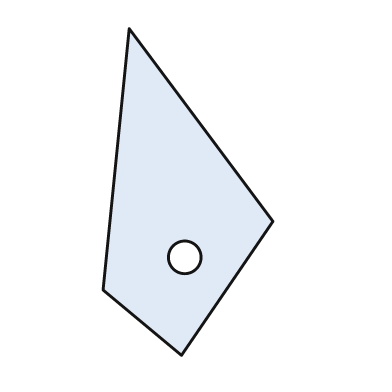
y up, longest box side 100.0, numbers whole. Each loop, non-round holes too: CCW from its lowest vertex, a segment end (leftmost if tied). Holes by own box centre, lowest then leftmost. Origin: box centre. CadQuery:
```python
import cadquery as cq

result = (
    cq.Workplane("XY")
    .moveTo(-2.0, -50.0)
    .lineTo(26.0, -9.0)
    .lineTo(-18.0, 50.0)
    .lineTo(-26.0, -30.0)
    .close()
    .moveTo(-1.0, -20.0)
    .circle(5.0)
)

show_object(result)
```